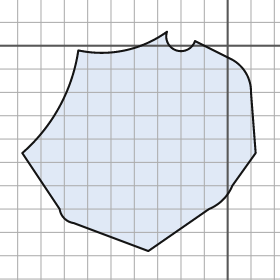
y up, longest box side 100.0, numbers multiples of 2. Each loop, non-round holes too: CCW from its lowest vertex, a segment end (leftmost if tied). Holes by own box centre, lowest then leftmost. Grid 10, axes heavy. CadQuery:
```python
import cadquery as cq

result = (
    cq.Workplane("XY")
    .moveTo(-34.0, -88.0)
    .lineTo(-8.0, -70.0)
    .threePointArc((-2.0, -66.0), (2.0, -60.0))
    .lineTo(12.0, -46.0)
    .lineTo(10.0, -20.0)
    .threePointArc((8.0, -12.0), (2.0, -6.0))
    .lineTo(-14.0, 2.0)
    .threePointArc((-22.0, -2.0), (-26.0, 6.0))
    .threePointArc((-44.0, -2.0), (-64.0, -2.0))
    .threePointArc((-72.0, -26.0), (-88.0, -46.0))
    .lineTo(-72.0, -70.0)
    .threePointArc((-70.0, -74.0), (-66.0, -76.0))
    .close()
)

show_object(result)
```